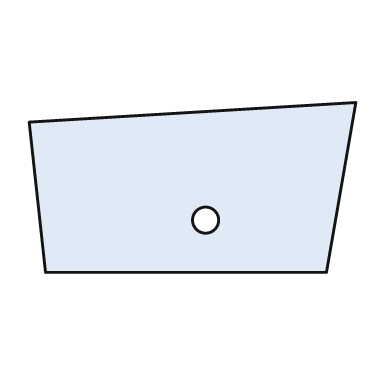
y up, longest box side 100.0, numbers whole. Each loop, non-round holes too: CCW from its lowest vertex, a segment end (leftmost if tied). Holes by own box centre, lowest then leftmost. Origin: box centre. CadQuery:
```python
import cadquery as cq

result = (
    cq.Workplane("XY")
    .moveTo(-45.0, -26.0)
    .lineTo(41.0, -26.0)
    .lineTo(50.0, 26.0)
    .lineTo(-50.0, 20.0)
    .close()
    .moveTo(4.0, -10.0)
    .circle(4.0)
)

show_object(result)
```